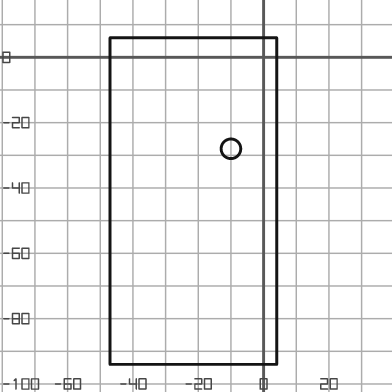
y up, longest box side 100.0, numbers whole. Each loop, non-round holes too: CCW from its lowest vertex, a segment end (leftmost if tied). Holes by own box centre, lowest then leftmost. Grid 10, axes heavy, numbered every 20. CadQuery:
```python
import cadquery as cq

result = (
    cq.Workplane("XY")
    .moveTo(-47.0, -94.0)
    .lineTo(4.0, -94.0)
    .lineTo(4.0, 6.0)
    .lineTo(-47.0, 6.0)
    .close()
    .moveTo(-10.0, -28.0)
    .circle(3.0)
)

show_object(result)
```